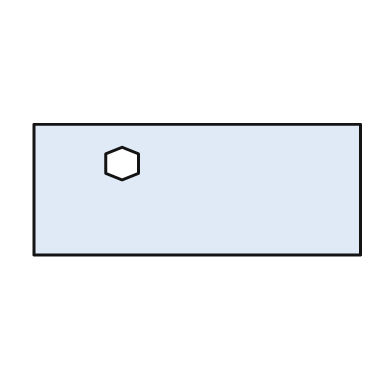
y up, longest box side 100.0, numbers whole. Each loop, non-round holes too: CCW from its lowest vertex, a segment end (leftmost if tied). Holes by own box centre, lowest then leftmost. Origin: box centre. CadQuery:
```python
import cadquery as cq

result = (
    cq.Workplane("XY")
    .moveTo(-50.0, -20.0)
    .lineTo(50.0, -20.0)
    .lineTo(50.0, 20.0)
    .lineTo(-50.0, 20.0)
    .close()
    .moveTo(-23.0, 3.0)
    .lineTo(-18.0, 5.0)
    .lineTo(-18.0, 11.0)
    .lineTo(-23.0, 13.0)
    .lineTo(-28.0, 11.0)
    .lineTo(-28.0, 5.0)
    .close()
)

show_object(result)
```